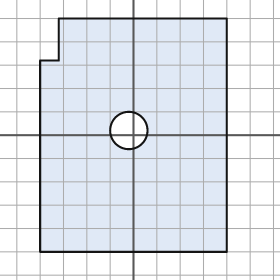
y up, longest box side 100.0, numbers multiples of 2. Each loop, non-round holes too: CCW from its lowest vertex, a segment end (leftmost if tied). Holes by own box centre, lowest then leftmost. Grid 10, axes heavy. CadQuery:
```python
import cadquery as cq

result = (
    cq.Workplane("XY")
    .moveTo(-40.0, -50.0)
    .lineTo(40.0, -50.0)
    .lineTo(40.0, 50.0)
    .lineTo(-32.0, 50.0)
    .lineTo(-32.0, 32.0)
    .lineTo(-40.0, 32.0)
    .close()
    .moveTo(-2.0, 2.0)
    .circle(8.0)
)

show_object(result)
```